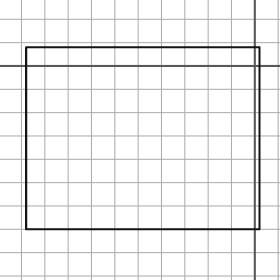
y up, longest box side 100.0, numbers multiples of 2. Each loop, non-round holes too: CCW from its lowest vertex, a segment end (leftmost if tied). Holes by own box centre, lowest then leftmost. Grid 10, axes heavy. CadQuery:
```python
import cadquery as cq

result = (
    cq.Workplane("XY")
    .moveTo(-98.0, -70.0)
    .lineTo(2.0, -70.0)
    .lineTo(2.0, 8.0)
    .lineTo(-98.0, 8.0)
    .close()
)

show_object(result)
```